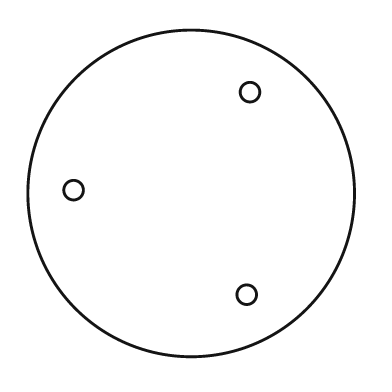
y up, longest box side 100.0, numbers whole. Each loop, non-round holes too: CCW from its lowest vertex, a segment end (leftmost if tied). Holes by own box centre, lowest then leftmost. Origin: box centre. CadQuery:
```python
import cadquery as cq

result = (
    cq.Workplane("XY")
    .moveTo(0.0, 0.0)
    .circle(50.0)
    .moveTo(17.0, -31.0)
    .circle(3.0)
    .moveTo(-36.0, 1.0)
    .circle(3.0)
    .moveTo(18.0, 31.0)
    .circle(3.0)
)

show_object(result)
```